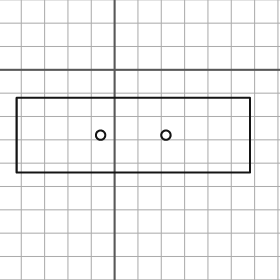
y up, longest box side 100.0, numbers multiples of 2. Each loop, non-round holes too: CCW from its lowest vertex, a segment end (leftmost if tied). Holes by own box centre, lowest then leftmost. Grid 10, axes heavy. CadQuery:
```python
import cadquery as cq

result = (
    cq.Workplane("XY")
    .moveTo(-42.0, -44.0)
    .lineTo(58.0, -44.0)
    .lineTo(58.0, -12.0)
    .lineTo(-42.0, -12.0)
    .close()
    .moveTo(-6.0, -28.0)
    .circle(2.0)
    .moveTo(22.0, -28.0)
    .circle(2.0)
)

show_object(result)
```